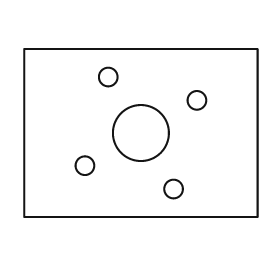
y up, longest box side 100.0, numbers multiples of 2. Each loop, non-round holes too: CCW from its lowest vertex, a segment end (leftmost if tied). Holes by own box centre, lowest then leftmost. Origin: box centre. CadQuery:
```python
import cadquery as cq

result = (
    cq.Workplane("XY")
    .moveTo(-50.0, -36.0)
    .lineTo(50.0, -36.0)
    .lineTo(50.0, 36.0)
    .lineTo(-50.0, 36.0)
    .close()
    .moveTo(14.0, -24.0)
    .circle(4.0)
    .moveTo(-24.0, -14.0)
    .circle(4.0)
    .moveTo(0.0, 0.0)
    .circle(12.0)
    .moveTo(24.0, 14.0)
    .circle(4.0)
    .moveTo(-14.0, 24.0)
    .circle(4.0)
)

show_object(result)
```